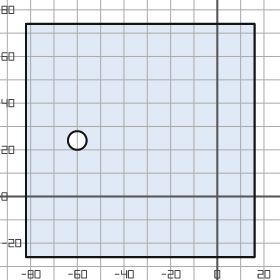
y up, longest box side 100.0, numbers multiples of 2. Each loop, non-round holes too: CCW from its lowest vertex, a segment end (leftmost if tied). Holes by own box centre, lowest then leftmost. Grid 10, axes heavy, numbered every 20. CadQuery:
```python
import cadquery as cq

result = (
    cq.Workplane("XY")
    .moveTo(-82.0, -26.0)
    .lineTo(16.0, -26.0)
    .lineTo(16.0, 74.0)
    .lineTo(-82.0, 74.0)
    .close()
    .moveTo(-60.0, 24.0)
    .circle(4.0)
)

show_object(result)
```